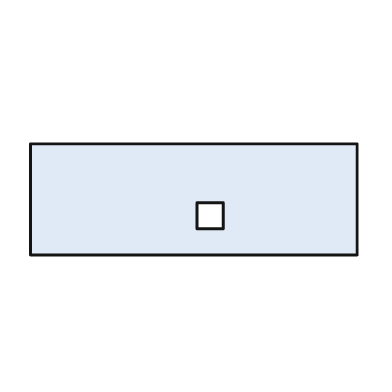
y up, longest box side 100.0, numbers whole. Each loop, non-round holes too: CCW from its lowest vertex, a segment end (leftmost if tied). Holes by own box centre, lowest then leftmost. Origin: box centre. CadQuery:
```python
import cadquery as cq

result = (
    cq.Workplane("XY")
    .moveTo(-50.0, -17.0)
    .lineTo(50.0, -17.0)
    .lineTo(50.0, 17.0)
    .lineTo(-50.0, 17.0)
    .close()
    .moveTo(1.0, -9.0)
    .lineTo(9.0, -9.0)
    .lineTo(9.0, -1.0)
    .lineTo(1.0, -1.0)
    .close()
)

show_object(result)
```